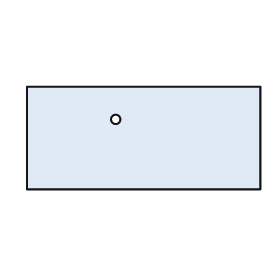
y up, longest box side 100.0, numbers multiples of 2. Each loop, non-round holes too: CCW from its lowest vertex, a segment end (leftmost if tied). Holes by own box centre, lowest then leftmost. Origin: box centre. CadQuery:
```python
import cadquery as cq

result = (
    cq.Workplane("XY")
    .moveTo(-50.0, -22.0)
    .lineTo(50.0, -22.0)
    .lineTo(50.0, 22.0)
    .lineTo(-50.0, 22.0)
    .close()
    .moveTo(-12.0, 8.0)
    .circle(2.0)
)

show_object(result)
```